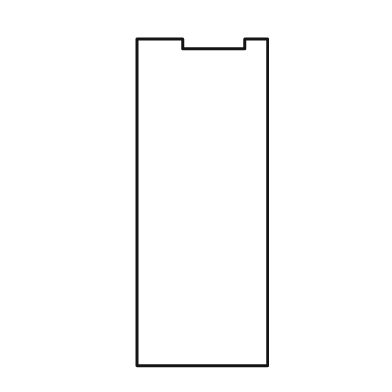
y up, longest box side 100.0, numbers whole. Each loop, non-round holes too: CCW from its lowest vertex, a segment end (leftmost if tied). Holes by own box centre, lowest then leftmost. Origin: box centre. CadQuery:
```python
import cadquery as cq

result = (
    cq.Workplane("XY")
    .moveTo(-20.0, -50.0)
    .lineTo(20.0, -50.0)
    .lineTo(20.0, 50.0)
    .lineTo(13.0, 50.0)
    .lineTo(13.0, 47.0)
    .lineTo(-6.0, 47.0)
    .lineTo(-6.0, 50.0)
    .lineTo(-20.0, 50.0)
    .close()
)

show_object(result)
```